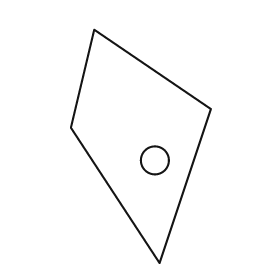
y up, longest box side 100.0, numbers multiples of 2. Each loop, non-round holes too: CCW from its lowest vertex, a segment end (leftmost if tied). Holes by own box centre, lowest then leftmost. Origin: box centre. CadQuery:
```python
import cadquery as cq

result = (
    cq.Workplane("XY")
    .moveTo(8.0, -50.0)
    .lineTo(30.0, 16.0)
    .lineTo(-20.0, 50.0)
    .lineTo(-30.0, 8.0)
    .close()
    .moveTo(6.0, -6.0)
    .circle(6.0)
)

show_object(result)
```